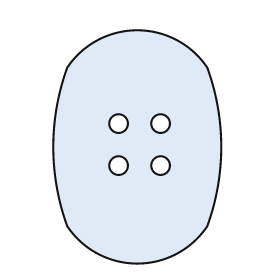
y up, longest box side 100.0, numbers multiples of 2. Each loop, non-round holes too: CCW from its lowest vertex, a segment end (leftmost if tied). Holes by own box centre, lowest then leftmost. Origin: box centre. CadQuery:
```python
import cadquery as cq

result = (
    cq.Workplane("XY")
    .moveTo(-30.0, -34.0)
    .threePointArc((0.0, -50.0), (30.0, -34.0))
    .threePointArc((36.0, 0.0), (30.0, 34.0))
    .threePointArc((0.0, 50.0), (-30.0, 34.0))
    .threePointArc((-36.0, 0.0), (-30.0, -34.0))
    .close()
    .moveTo(-8.0, -8.0)
    .circle(4.0)
    .moveTo(10.0, -8.0)
    .circle(4.0)
    .moveTo(-8.0, 10.0)
    .circle(4.0)
    .moveTo(10.0, 10.0)
    .circle(4.0)
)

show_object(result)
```